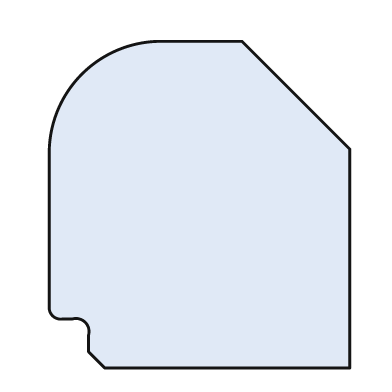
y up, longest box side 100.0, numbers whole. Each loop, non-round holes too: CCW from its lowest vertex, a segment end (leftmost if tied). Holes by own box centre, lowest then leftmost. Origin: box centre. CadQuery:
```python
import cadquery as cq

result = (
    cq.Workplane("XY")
    .moveTo(-29.0, -50.0)
    .lineTo(46.0, -50.0)
    .lineTo(46.0, 17.0)
    .lineTo(13.0, 50.0)
    .lineTo(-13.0, 50.0)
    .threePointArc((-36.0, 40.0), (-46.0, 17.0))
    .lineTo(-46.0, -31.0)
    .threePointArc((-45.0, -34.0), (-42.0, -35.0))
    .lineTo(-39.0, -35.0)
    .threePointArc((-35.0, -36.0), (-34.0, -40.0))
    .lineTo(-34.0, -45.0)
    .close()
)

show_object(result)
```